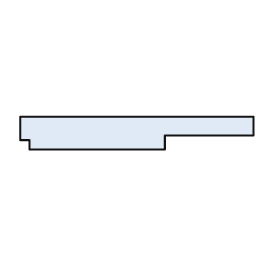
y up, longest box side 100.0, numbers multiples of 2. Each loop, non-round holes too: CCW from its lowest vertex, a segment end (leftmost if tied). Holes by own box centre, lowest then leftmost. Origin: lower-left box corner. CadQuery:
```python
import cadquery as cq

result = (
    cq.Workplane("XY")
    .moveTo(4.0, 0.0)
    .lineTo(62.0, 0.0)
    .lineTo(62.0, 6.0)
    .lineTo(100.0, 6.0)
    .lineTo(100.0, 14.0)
    .lineTo(0.0, 14.0)
    .lineTo(0.0, 4.0)
    .lineTo(4.0, 4.0)
    .close()
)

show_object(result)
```